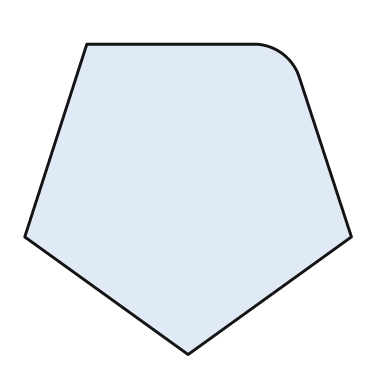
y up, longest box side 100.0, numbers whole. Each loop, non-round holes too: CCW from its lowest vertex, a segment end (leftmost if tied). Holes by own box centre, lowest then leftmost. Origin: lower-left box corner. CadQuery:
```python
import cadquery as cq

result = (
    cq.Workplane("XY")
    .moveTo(50.0, 0.0)
    .lineTo(100.0, 36.0)
    .lineTo(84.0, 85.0)
    .threePointArc((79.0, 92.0), (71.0, 95.0))
    .lineTo(19.0, 95.0)
    .lineTo(0.0, 36.0)
    .close()
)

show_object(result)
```